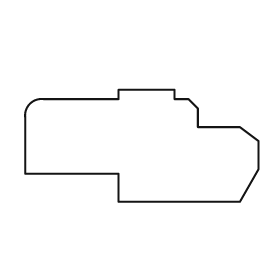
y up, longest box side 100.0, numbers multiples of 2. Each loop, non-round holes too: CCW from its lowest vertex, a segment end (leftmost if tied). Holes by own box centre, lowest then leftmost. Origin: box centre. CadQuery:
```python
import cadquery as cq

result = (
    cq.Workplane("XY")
    .moveTo(-10.0, -24.0)
    .lineTo(42.0, -24.0)
    .lineTo(50.0, -10.0)
    .lineTo(50.0, 2.0)
    .lineTo(42.0, 8.0)
    .lineTo(24.0, 8.0)
    .lineTo(24.0, 16.0)
    .lineTo(20.0, 20.0)
    .lineTo(14.0, 20.0)
    .lineTo(14.0, 24.0)
    .lineTo(-10.0, 24.0)
    .lineTo(-10.0, 20.0)
    .lineTo(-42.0, 20.0)
    .threePointArc((-48.0, 18.0), (-50.0, 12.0))
    .lineTo(-50.0, -12.0)
    .lineTo(-10.0, -12.0)
    .close()
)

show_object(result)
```